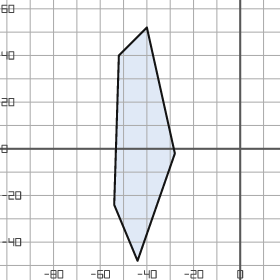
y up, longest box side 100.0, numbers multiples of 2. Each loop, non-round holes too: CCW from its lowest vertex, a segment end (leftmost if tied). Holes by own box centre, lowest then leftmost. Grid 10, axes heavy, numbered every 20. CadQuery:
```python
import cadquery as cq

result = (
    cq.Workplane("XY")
    .moveTo(-44.0, -48.0)
    .lineTo(-28.0, -2.0)
    .lineTo(-40.0, 52.0)
    .lineTo(-52.0, 40.0)
    .lineTo(-54.0, -24.0)
    .close()
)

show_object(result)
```